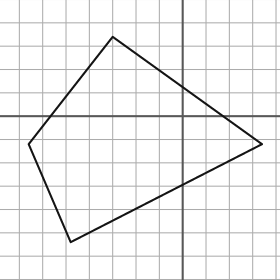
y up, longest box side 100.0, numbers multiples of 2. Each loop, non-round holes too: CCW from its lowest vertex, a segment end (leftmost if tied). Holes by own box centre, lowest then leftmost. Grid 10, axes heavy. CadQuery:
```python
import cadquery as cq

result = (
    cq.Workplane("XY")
    .moveTo(-48.0, -54.0)
    .lineTo(34.0, -12.0)
    .lineTo(-30.0, 34.0)
    .lineTo(-66.0, -12.0)
    .close()
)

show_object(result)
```